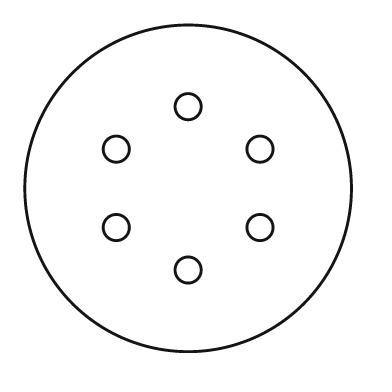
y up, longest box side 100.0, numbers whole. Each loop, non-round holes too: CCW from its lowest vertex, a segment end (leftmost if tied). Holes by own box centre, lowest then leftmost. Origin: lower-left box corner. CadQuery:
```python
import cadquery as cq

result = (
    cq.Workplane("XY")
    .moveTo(50.0, 50.0)
    .circle(50.0)
    .moveTo(50.0, 25.0)
    .circle(4.0)
    .moveTo(28.0, 38.0)
    .circle(4.0)
    .moveTo(72.0, 38.0)
    .circle(4.0)
    .moveTo(28.0, 62.0)
    .circle(4.0)
    .moveTo(72.0, 62.0)
    .circle(4.0)
    .moveTo(50.0, 75.0)
    .circle(4.0)
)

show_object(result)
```